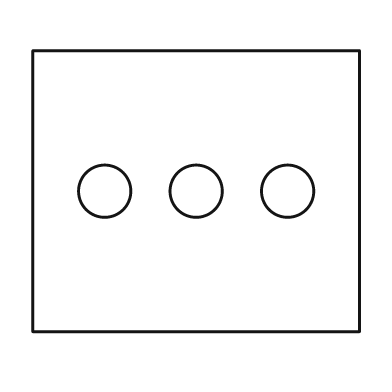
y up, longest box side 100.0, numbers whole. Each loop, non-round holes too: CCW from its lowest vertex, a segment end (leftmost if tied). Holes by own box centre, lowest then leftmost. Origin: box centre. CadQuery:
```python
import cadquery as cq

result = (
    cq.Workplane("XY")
    .moveTo(-50.0, -43.0)
    .lineTo(50.0, -43.0)
    .lineTo(50.0, 43.0)
    .lineTo(-50.0, 43.0)
    .close()
    .moveTo(-28.0, 0.0)
    .circle(8.0)
    .moveTo(0.0, 0.0)
    .circle(8.0)
    .moveTo(28.0, 0.0)
    .circle(8.0)
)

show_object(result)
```